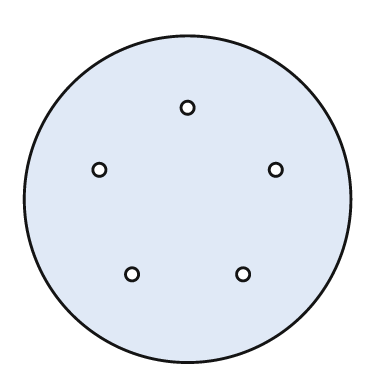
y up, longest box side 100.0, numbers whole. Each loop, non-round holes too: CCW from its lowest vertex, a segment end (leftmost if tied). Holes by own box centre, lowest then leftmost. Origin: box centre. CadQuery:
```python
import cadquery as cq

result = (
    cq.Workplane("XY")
    .moveTo(0.0, 0.0)
    .circle(50.0)
    .moveTo(-17.0, -23.0)
    .circle(2.0)
    .moveTo(17.0, -23.0)
    .circle(2.0)
    .moveTo(-27.0, 9.0)
    .circle(2.0)
    .moveTo(27.0, 9.0)
    .circle(2.0)
    .moveTo(0.0, 28.0)
    .circle(2.0)
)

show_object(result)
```